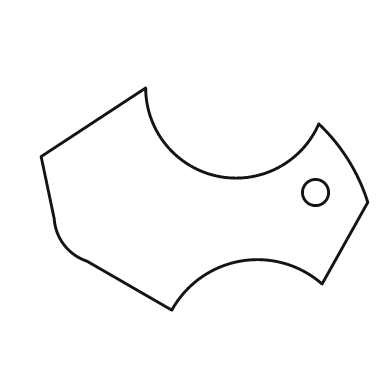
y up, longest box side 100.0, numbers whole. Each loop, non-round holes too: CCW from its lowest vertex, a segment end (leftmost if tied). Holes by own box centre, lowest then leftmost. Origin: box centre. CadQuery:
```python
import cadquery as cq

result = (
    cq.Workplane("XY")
    .moveTo(-10.0, -34.0)
    .threePointArc((11.0, -19.0), (36.0, -26.0))
    .lineTo(50.0, -1.0)
    .threePointArc((44.0, 12.0), (35.0, 23.0))
    .threePointArc((4.0, 7.0), (-18.0, 34.0))
    .lineTo(-50.0, 13.0)
    .lineTo(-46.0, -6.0)
    .threePointArc((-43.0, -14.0), (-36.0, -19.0))
    .close()
    .moveTo(34.0, 2.0)
    .circle(4.0)
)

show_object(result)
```